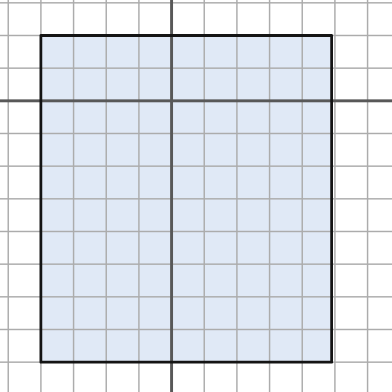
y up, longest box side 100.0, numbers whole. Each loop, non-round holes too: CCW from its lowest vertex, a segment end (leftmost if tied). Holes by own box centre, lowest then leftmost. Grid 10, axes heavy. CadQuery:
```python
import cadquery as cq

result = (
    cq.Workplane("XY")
    .moveTo(-40.0, -80.0)
    .lineTo(49.0, -80.0)
    .lineTo(49.0, 20.0)
    .lineTo(-40.0, 20.0)
    .close()
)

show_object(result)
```